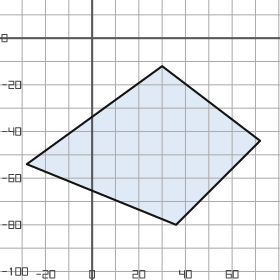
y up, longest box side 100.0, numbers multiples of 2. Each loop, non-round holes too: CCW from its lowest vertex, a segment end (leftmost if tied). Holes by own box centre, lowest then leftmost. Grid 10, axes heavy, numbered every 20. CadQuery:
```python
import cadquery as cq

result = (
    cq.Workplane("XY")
    .moveTo(36.0, -80.0)
    .lineTo(72.0, -44.0)
    .lineTo(30.0, -12.0)
    .lineTo(-28.0, -54.0)
    .close()
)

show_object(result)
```